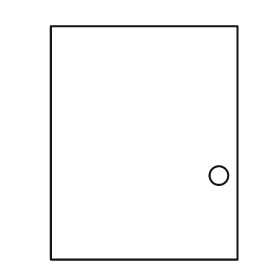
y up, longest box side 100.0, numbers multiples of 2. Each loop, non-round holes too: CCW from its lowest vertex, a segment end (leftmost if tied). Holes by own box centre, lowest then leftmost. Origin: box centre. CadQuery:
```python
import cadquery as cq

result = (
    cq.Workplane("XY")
    .moveTo(-40.0, -50.0)
    .lineTo(40.0, -50.0)
    .lineTo(40.0, 50.0)
    .lineTo(-40.0, 50.0)
    .close()
    .moveTo(32.0, -14.0)
    .circle(4.0)
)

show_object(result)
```